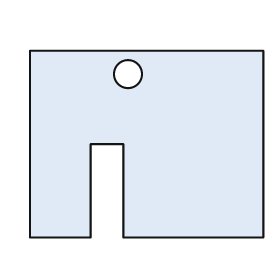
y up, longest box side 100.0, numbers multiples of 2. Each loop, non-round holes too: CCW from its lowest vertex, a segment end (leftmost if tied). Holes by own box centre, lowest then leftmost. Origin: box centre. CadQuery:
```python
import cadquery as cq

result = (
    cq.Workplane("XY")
    .moveTo(-50.0, -40.0)
    .lineTo(-24.0, -40.0)
    .lineTo(-24.0, 0.0)
    .lineTo(-10.0, 0.0)
    .lineTo(-10.0, -40.0)
    .lineTo(50.0, -40.0)
    .lineTo(50.0, 40.0)
    .lineTo(-50.0, 40.0)
    .close()
    .moveTo(-8.0, 30.0)
    .circle(6.0)
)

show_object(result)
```